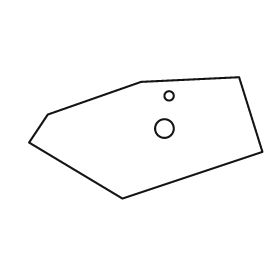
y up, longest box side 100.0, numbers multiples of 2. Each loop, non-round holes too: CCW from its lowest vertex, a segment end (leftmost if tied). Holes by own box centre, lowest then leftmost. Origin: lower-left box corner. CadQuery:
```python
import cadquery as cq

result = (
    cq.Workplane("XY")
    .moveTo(40.0, 0.0)
    .lineTo(100.0, 20.0)
    .lineTo(90.0, 52.0)
    .lineTo(48.0, 50.0)
    .lineTo(8.0, 36.0)
    .lineTo(0.0, 24.0)
    .close()
    .moveTo(58.0, 30.0)
    .circle(4.0)
    .moveTo(60.0, 44.0)
    .circle(2.0)
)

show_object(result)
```